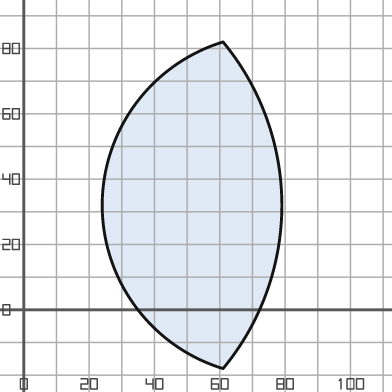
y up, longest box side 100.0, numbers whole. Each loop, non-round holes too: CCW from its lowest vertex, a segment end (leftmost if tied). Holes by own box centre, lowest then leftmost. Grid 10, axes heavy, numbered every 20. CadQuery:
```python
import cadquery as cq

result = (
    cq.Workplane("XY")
    .moveTo(61.0, -18.0)
    .threePointArc((79.0, 32.0), (61.0, 82.0))
    .threePointArc((24.0, 32.0), (61.0, -18.0))
    .close()
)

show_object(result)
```